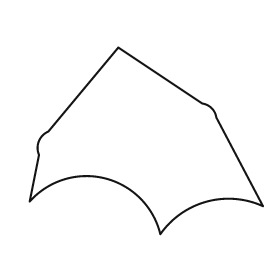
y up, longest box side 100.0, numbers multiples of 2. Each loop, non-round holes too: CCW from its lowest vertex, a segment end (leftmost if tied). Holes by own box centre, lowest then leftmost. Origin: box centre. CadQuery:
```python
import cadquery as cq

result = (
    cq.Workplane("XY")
    .moveTo(6.0, -40.0)
    .threePointArc((26.0, -26.0), (50.0, -28.0))
    .lineTo(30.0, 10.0)
    .threePointArc((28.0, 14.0), (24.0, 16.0))
    .lineTo(-12.0, 40.0)
    .lineTo(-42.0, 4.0)
    .threePointArc((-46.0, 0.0), (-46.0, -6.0))
    .lineTo(-50.0, -26.0)
    .threePointArc((-18.0, -16.0), (6.0, -40.0))
    .close()
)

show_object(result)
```